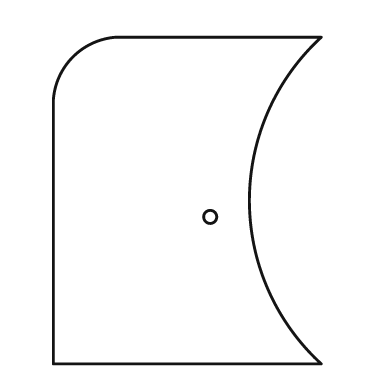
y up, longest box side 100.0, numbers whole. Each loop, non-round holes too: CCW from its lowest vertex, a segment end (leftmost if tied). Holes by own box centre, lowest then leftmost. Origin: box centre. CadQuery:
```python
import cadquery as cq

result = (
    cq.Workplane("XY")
    .moveTo(-41.0, -50.0)
    .lineTo(41.0, -50.0)
    .threePointArc((19.0, 0.0), (41.0, 50.0))
    .lineTo(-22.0, 50.0)
    .threePointArc((-35.0, 44.0), (-41.0, 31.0))
    .close()
    .moveTo(7.0, -5.0)
    .circle(2.0)
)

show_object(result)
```